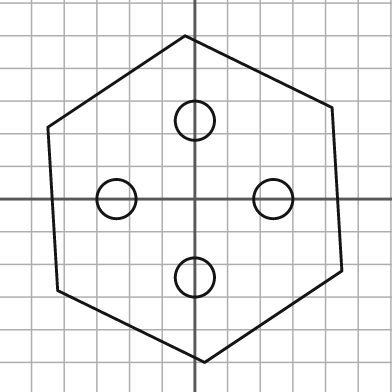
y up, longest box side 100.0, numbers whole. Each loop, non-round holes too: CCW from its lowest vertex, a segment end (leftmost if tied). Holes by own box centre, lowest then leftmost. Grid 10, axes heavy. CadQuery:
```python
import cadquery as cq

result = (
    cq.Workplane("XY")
    .moveTo(3.0, -50.0)
    .lineTo(45.0, -22.0)
    .lineTo(42.0, 28.0)
    .lineTo(-3.0, 50.0)
    .lineTo(-45.0, 22.0)
    .lineTo(-42.0, -28.0)
    .close()
    .moveTo(0.0, -24.0)
    .circle(6.0)
    .moveTo(-24.0, 0.0)
    .circle(6.0)
    .moveTo(24.0, 0.0)
    .circle(6.0)
    .moveTo(0.0, 24.0)
    .circle(6.0)
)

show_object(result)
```